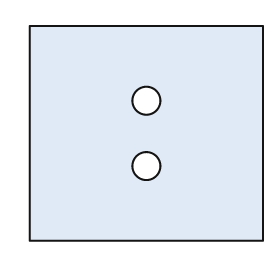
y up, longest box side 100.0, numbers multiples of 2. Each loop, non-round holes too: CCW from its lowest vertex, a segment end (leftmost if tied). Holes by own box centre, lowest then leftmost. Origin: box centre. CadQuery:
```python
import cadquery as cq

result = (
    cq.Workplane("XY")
    .moveTo(-50.0, -46.0)
    .lineTo(50.0, -46.0)
    .lineTo(50.0, 46.0)
    .lineTo(-50.0, 46.0)
    .close()
    .moveTo(0.0, -14.0)
    .circle(6.0)
    .moveTo(0.0, 14.0)
    .circle(6.0)
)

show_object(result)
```